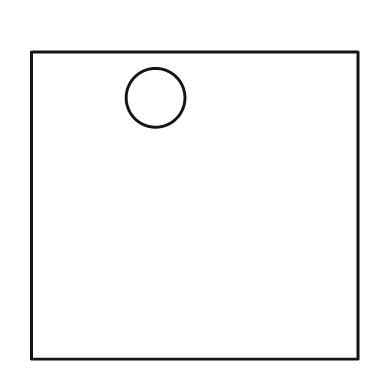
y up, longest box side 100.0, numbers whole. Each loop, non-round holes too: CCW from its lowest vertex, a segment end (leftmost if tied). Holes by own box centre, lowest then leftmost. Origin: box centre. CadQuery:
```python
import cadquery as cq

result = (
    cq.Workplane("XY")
    .moveTo(-50.0, -47.0)
    .lineTo(50.0, -47.0)
    .lineTo(50.0, 47.0)
    .lineTo(-50.0, 47.0)
    .close()
    .moveTo(-12.0, 33.0)
    .circle(9.0)
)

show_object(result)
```